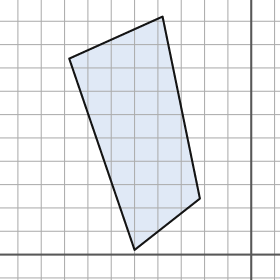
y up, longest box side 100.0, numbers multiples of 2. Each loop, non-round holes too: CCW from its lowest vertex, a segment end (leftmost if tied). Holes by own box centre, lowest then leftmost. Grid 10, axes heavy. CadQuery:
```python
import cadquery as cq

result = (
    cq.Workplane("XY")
    .moveTo(-50.0, 2.0)
    .lineTo(-22.0, 24.0)
    .lineTo(-38.0, 102.0)
    .lineTo(-78.0, 84.0)
    .close()
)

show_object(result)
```